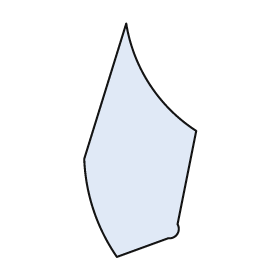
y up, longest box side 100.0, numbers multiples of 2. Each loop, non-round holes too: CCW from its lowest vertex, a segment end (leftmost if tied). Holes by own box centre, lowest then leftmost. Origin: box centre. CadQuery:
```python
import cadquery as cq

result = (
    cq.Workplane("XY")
    .moveTo(-10.0, -50.0)
    .lineTo(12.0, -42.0)
    .threePointArc((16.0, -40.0), (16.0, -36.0))
    .lineTo(24.0, 4.0)
    .threePointArc((4.0, 24.0), (-6.0, 50.0))
    .lineTo(-24.0, -8.0)
    .threePointArc((-20.0, -30.0), (-10.0, -50.0))
    .close()
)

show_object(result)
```